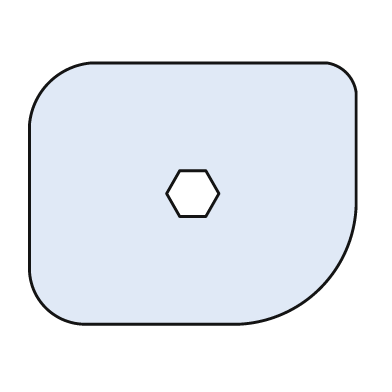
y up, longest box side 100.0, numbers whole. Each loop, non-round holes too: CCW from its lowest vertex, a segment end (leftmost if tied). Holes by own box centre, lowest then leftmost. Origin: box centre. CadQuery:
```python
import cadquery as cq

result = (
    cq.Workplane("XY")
    .moveTo(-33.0, -40.0)
    .lineTo(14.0, -40.0)
    .threePointArc((39.0, -29.0), (50.0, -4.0))
    .lineTo(50.0, 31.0)
    .threePointArc((47.0, 37.0), (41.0, 40.0))
    .lineTo(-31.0, 40.0)
    .threePointArc((-44.0, 34.0), (-50.0, 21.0))
    .lineTo(-50.0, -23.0)
    .threePointArc((-45.0, -35.0), (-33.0, -40.0))
    .close()
    .moveTo(-4.0, -7.0)
    .lineTo(4.0, -7.0)
    .lineTo(8.0, 0.0)
    .lineTo(4.0, 7.0)
    .lineTo(-4.0, 7.0)
    .lineTo(-8.0, 0.0)
    .close()
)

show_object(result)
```